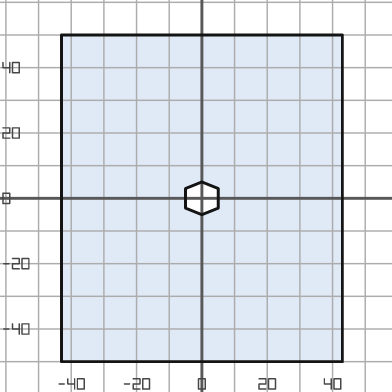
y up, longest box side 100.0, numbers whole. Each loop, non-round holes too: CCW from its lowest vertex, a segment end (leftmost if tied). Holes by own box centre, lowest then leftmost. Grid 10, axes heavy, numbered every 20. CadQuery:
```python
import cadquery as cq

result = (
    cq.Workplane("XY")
    .moveTo(-43.0, -50.0)
    .lineTo(43.0, -50.0)
    .lineTo(43.0, 50.0)
    .lineTo(-43.0, 50.0)
    .close()
    .moveTo(0.0, -5.0)
    .lineTo(5.0, -3.0)
    .lineTo(5.0, 3.0)
    .lineTo(0.0, 5.0)
    .lineTo(-5.0, 3.0)
    .lineTo(-5.0, -3.0)
    .close()
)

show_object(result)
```